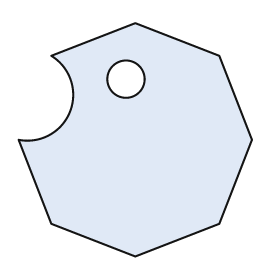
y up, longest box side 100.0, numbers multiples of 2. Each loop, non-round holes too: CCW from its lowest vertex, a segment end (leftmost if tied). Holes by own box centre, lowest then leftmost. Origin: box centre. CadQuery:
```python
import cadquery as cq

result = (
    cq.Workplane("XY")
    .moveTo(0.0, -50.0)
    .lineTo(36.0, -36.0)
    .lineTo(50.0, 0.0)
    .lineTo(36.0, 36.0)
    .lineTo(0.0, 50.0)
    .lineTo(-36.0, 36.0)
    .threePointArc((-28.0, 12.0), (-50.0, 0.0))
    .lineTo(-36.0, -36.0)
    .close()
    .moveTo(-4.0, 26.0)
    .circle(8.0)
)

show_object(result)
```